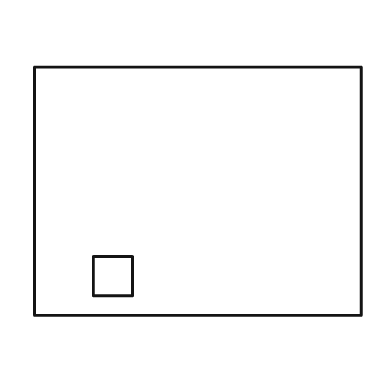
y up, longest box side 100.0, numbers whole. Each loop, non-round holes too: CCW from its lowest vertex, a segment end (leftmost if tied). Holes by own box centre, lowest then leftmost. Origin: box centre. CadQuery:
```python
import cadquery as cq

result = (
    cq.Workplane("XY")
    .moveTo(-50.0, -38.0)
    .lineTo(50.0, -38.0)
    .lineTo(50.0, 38.0)
    .lineTo(-50.0, 38.0)
    .close()
    .moveTo(-32.0, -32.0)
    .lineTo(-20.0, -32.0)
    .lineTo(-20.0, -20.0)
    .lineTo(-32.0, -20.0)
    .close()
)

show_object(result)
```